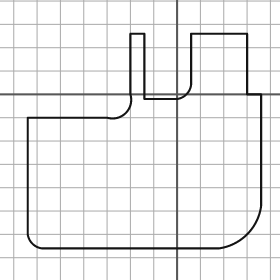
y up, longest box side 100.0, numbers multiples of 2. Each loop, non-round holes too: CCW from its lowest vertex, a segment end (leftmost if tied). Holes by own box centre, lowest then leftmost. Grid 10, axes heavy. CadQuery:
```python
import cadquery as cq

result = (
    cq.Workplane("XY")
    .moveTo(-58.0, -66.0)
    .lineTo(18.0, -66.0)
    .threePointArc((30.0, -60.0), (36.0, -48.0))
    .lineTo(36.0, 0.0)
    .lineTo(30.0, 0.0)
    .lineTo(30.0, 26.0)
    .lineTo(6.0, 26.0)
    .lineTo(6.0, 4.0)
    .threePointArc((4.0, 0.0), (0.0, -2.0))
    .lineTo(-14.0, -2.0)
    .lineTo(-14.0, 26.0)
    .lineTo(-20.0, 26.0)
    .lineTo(-20.0, 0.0)
    .threePointArc((-22.0, -8.0), (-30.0, -10.0))
    .lineTo(-64.0, -10.0)
    .lineTo(-64.0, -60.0)
    .threePointArc((-62.0, -64.0), (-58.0, -66.0))
    .close()
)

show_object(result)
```